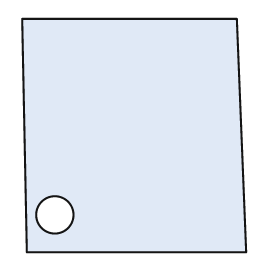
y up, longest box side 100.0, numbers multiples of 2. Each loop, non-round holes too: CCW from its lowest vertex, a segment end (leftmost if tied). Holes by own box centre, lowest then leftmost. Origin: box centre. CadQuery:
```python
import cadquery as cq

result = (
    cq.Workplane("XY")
    .moveTo(-46.0, -50.0)
    .lineTo(48.0, -50.0)
    .lineTo(44.0, 50.0)
    .lineTo(-48.0, 50.0)
    .close()
    .moveTo(-34.0, -34.0)
    .circle(8.0)
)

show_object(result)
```